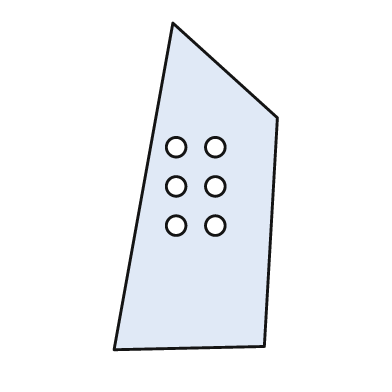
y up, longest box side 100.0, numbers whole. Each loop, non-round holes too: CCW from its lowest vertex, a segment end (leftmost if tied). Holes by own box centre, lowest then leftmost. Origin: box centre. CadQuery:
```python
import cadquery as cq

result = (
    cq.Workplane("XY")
    .moveTo(-25.0, -50.0)
    .lineTo(21.0, -49.0)
    .lineTo(25.0, 21.0)
    .lineTo(-7.0, 50.0)
    .close()
    .moveTo(-6.0, -12.0)
    .circle(3.0)
    .moveTo(6.0, -12.0)
    .circle(3.0)
    .moveTo(-6.0, 0.0)
    .circle(3.0)
    .moveTo(6.0, 0.0)
    .circle(3.0)
    .moveTo(-6.0, 12.0)
    .circle(3.0)
    .moveTo(6.0, 12.0)
    .circle(3.0)
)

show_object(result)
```